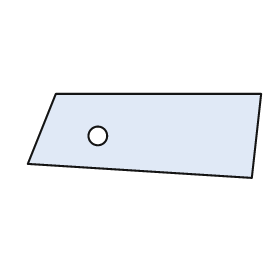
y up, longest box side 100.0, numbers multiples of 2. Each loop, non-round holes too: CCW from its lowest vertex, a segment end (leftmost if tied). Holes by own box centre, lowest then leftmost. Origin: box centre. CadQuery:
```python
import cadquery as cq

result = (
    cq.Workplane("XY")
    .moveTo(46.0, -18.0)
    .lineTo(50.0, 18.0)
    .lineTo(-38.0, 18.0)
    .lineTo(-50.0, -12.0)
    .close()
    .moveTo(-20.0, 0.0)
    .circle(4.0)
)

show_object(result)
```